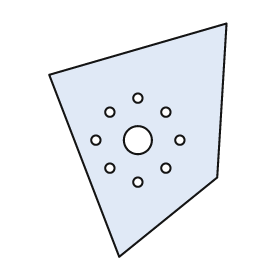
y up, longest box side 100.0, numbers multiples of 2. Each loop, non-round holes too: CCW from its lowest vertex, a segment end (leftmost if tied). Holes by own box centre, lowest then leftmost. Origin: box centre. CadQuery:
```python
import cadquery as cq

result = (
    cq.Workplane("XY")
    .moveTo(-8.0, -50.0)
    .lineTo(34.0, -16.0)
    .lineTo(38.0, 50.0)
    .lineTo(-38.0, 28.0)
    .close()
    .moveTo(0.0, -18.0)
    .circle(2.0)
    .moveTo(-12.0, -12.0)
    .circle(2.0)
    .moveTo(12.0, -12.0)
    .circle(2.0)
    .moveTo(-18.0, 0.0)
    .circle(2.0)
    .moveTo(0.0, 0.0)
    .circle(6.0)
    .moveTo(18.0, 0.0)
    .circle(2.0)
    .moveTo(-12.0, 12.0)
    .circle(2.0)
    .moveTo(12.0, 12.0)
    .circle(2.0)
    .moveTo(0.0, 18.0)
    .circle(2.0)
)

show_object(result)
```